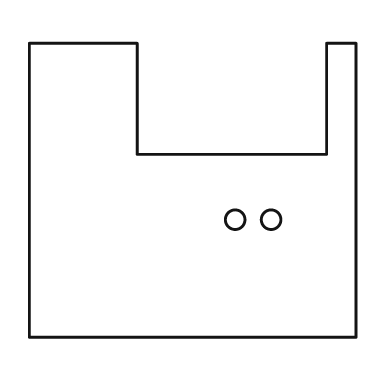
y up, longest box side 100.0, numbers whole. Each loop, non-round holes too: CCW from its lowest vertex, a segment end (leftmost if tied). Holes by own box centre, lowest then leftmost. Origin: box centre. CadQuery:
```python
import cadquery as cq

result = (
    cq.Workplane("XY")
    .moveTo(-50.0, -45.0)
    .lineTo(50.0, -45.0)
    .lineTo(50.0, 45.0)
    .lineTo(41.0, 45.0)
    .lineTo(41.0, 11.0)
    .lineTo(-17.0, 11.0)
    .lineTo(-17.0, 45.0)
    .lineTo(-50.0, 45.0)
    .close()
    .moveTo(13.0, -9.0)
    .circle(3.0)
    .moveTo(24.0, -9.0)
    .circle(3.0)
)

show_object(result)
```